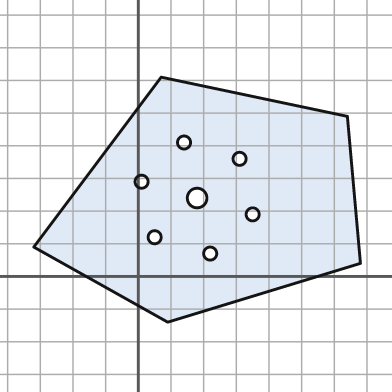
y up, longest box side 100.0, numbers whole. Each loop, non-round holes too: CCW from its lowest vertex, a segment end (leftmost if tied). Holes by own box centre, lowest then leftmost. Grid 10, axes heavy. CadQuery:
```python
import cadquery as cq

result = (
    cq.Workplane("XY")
    .moveTo(9.0, -14.0)
    .lineTo(68.0, 4.0)
    .lineTo(64.0, 49.0)
    .lineTo(7.0, 61.0)
    .lineTo(-32.0, 9.0)
    .close()
    .moveTo(22.0, 7.0)
    .circle(2.0)
    .moveTo(5.0, 12.0)
    .circle(2.0)
    .moveTo(35.0, 19.0)
    .circle(2.0)
    .moveTo(18.0, 24.0)
    .circle(3.0)
    .moveTo(1.0, 29.0)
    .circle(2.0)
    .moveTo(31.0, 36.0)
    .circle(2.0)
    .moveTo(14.0, 41.0)
    .circle(2.0)
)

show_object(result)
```